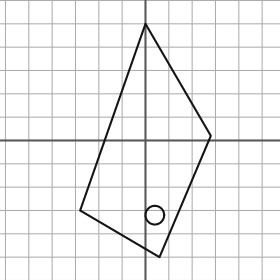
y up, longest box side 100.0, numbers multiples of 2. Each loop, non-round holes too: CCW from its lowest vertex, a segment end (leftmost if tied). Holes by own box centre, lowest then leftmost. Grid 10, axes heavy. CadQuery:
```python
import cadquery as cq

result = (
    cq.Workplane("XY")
    .moveTo(6.0, -50.0)
    .lineTo(28.0, 2.0)
    .lineTo(0.0, 50.0)
    .lineTo(-28.0, -30.0)
    .close()
    .moveTo(4.0, -32.0)
    .circle(4.0)
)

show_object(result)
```